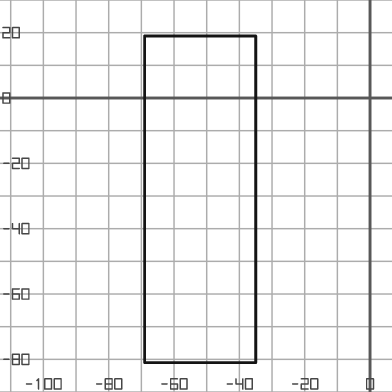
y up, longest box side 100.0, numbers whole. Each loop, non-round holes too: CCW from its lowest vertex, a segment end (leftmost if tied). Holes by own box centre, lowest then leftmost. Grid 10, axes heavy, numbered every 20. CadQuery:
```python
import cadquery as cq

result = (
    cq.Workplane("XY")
    .moveTo(-69.0, -81.0)
    .lineTo(-35.0, -81.0)
    .lineTo(-35.0, 19.0)
    .lineTo(-69.0, 19.0)
    .close()
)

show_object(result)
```